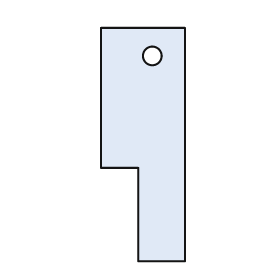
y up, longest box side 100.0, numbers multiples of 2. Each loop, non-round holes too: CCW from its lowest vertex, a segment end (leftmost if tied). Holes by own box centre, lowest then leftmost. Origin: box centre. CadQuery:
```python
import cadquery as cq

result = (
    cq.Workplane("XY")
    .moveTo(-2.0, -50.0)
    .lineTo(18.0, -50.0)
    .lineTo(18.0, 50.0)
    .lineTo(-18.0, 50.0)
    .lineTo(-18.0, -10.0)
    .lineTo(-2.0, -10.0)
    .close()
    .moveTo(4.0, 38.0)
    .circle(4.0)
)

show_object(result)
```